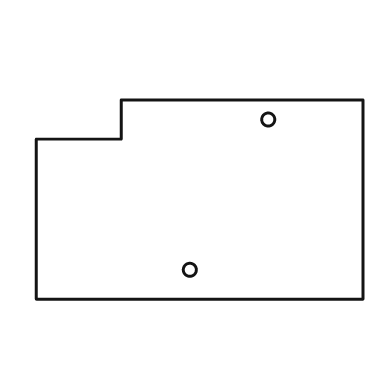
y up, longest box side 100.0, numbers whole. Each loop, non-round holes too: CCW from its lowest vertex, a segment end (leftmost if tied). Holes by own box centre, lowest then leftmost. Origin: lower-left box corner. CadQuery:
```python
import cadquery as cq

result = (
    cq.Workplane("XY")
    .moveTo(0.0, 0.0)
    .lineTo(100.0, 0.0)
    .lineTo(100.0, 61.0)
    .lineTo(26.0, 61.0)
    .lineTo(26.0, 49.0)
    .lineTo(0.0, 49.0)
    .close()
    .moveTo(47.0, 9.0)
    .circle(2.0)
    .moveTo(71.0, 55.0)
    .circle(2.0)
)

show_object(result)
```